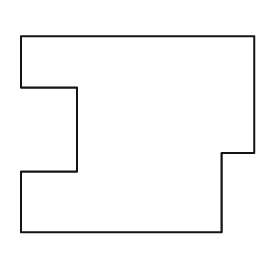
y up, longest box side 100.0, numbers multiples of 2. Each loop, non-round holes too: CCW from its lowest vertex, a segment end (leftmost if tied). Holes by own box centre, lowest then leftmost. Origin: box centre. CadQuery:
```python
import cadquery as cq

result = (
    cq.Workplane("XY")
    .moveTo(-50.0, -42.0)
    .lineTo(36.0, -42.0)
    .lineTo(36.0, -8.0)
    .lineTo(50.0, -8.0)
    .lineTo(50.0, 42.0)
    .lineTo(-50.0, 42.0)
    .lineTo(-50.0, 20.0)
    .lineTo(-26.0, 20.0)
    .lineTo(-26.0, -16.0)
    .lineTo(-50.0, -16.0)
    .close()
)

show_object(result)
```